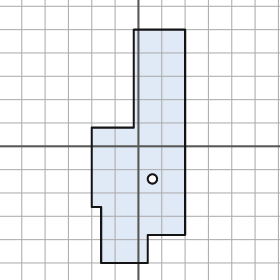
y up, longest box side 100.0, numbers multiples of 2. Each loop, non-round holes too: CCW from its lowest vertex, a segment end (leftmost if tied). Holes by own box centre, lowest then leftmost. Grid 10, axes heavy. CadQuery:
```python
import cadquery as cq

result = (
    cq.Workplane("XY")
    .moveTo(-16.0, -50.0)
    .lineTo(4.0, -50.0)
    .lineTo(4.0, -38.0)
    .lineTo(20.0, -38.0)
    .lineTo(20.0, 50.0)
    .lineTo(-2.0, 50.0)
    .lineTo(-2.0, 8.0)
    .lineTo(-20.0, 8.0)
    .lineTo(-20.0, -26.0)
    .lineTo(-16.0, -26.0)
    .close()
    .moveTo(6.0, -14.0)
    .circle(2.0)
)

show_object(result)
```